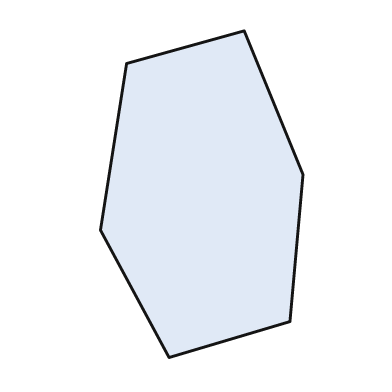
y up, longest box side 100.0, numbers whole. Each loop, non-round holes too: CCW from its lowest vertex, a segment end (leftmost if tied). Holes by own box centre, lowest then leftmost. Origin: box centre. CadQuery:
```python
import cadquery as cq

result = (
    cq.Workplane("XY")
    .moveTo(-10.0, -50.0)
    .lineTo(27.0, -39.0)
    .lineTo(31.0, 6.0)
    .lineTo(13.0, 50.0)
    .lineTo(-23.0, 40.0)
    .lineTo(-31.0, -11.0)
    .close()
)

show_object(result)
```